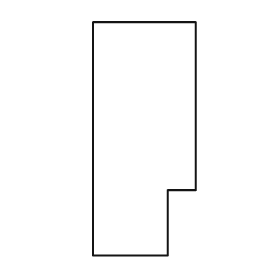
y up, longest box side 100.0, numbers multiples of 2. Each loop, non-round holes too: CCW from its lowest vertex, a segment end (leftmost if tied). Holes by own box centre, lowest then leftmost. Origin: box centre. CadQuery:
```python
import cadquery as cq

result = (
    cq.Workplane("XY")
    .moveTo(-22.0, -50.0)
    .lineTo(10.0, -50.0)
    .lineTo(10.0, -22.0)
    .lineTo(22.0, -22.0)
    .lineTo(22.0, 50.0)
    .lineTo(-22.0, 50.0)
    .close()
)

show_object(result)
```